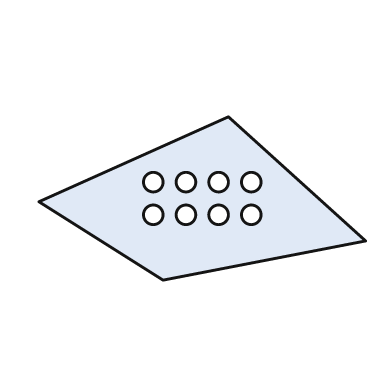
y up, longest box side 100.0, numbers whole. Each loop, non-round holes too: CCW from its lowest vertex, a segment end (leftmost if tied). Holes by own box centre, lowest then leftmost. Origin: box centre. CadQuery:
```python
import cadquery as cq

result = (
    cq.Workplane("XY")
    .moveTo(-12.0, -25.0)
    .lineTo(50.0, -13.0)
    .lineTo(8.0, 25.0)
    .lineTo(-50.0, -1.0)
    .close()
    .moveTo(-15.0, -5.0)
    .circle(3.0)
    .moveTo(-5.0, -5.0)
    .circle(3.0)
    .moveTo(5.0, -5.0)
    .circle(3.0)
    .moveTo(15.0, -5.0)
    .circle(3.0)
    .moveTo(-15.0, 5.0)
    .circle(3.0)
    .moveTo(-5.0, 5.0)
    .circle(3.0)
    .moveTo(5.0, 5.0)
    .circle(3.0)
    .moveTo(15.0, 5.0)
    .circle(3.0)
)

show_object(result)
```